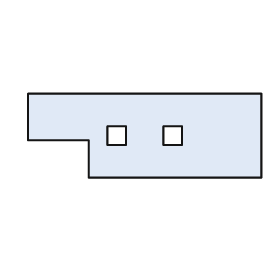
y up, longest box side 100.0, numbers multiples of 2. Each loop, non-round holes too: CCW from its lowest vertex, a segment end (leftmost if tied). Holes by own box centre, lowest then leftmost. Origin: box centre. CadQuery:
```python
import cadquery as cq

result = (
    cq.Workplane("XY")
    .moveTo(-24.0, -18.0)
    .lineTo(50.0, -18.0)
    .lineTo(50.0, 18.0)
    .lineTo(-50.0, 18.0)
    .lineTo(-50.0, -2.0)
    .lineTo(-24.0, -2.0)
    .close()
    .moveTo(-16.0, -4.0)
    .lineTo(-8.0, -4.0)
    .lineTo(-8.0, 4.0)
    .lineTo(-16.0, 4.0)
    .close()
    .moveTo(8.0, -4.0)
    .lineTo(16.0, -4.0)
    .lineTo(16.0, 4.0)
    .lineTo(8.0, 4.0)
    .close()
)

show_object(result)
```